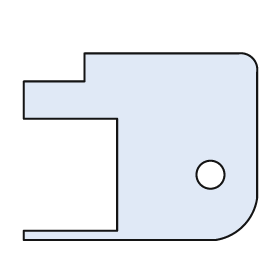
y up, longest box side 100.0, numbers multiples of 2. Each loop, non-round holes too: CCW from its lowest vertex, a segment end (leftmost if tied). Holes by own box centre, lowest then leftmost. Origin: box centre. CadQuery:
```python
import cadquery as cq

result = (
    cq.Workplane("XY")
    .moveTo(-50.0, -40.0)
    .lineTo(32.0, -40.0)
    .threePointArc((44.0, -34.0), (50.0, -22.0))
    .lineTo(50.0, 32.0)
    .threePointArc((48.0, 38.0), (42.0, 40.0))
    .lineTo(-24.0, 40.0)
    .lineTo(-24.0, 28.0)
    .lineTo(-50.0, 28.0)
    .lineTo(-50.0, 12.0)
    .lineTo(-10.0, 12.0)
    .lineTo(-10.0, -36.0)
    .lineTo(-50.0, -36.0)
    .close()
    .moveTo(30.0, -12.0)
    .circle(6.0)
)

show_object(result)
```